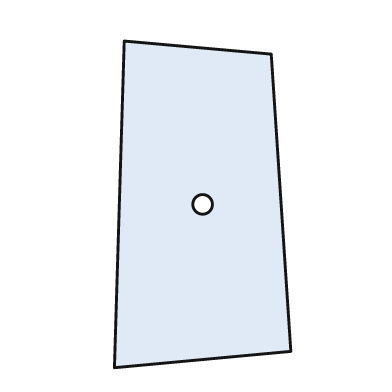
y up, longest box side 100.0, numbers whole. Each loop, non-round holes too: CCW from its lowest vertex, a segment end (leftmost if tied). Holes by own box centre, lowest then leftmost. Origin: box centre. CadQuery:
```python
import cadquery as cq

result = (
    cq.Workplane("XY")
    .moveTo(-27.0, -50.0)
    .lineTo(27.0, -45.0)
    .lineTo(21.0, 46.0)
    .lineTo(-24.0, 50.0)
    .close()
    .moveTo(0.0, 0.0)
    .circle(3.0)
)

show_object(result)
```